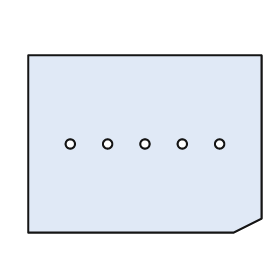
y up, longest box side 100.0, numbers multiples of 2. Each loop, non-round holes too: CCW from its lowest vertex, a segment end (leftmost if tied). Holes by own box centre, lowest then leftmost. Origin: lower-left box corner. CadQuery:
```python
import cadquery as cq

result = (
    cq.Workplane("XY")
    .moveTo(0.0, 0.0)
    .lineTo(88.0, 0.0)
    .lineTo(100.0, 6.0)
    .lineTo(100.0, 76.0)
    .lineTo(0.0, 76.0)
    .close()
    .moveTo(18.0, 38.0)
    .circle(2.0)
    .moveTo(34.0, 38.0)
    .circle(2.0)
    .moveTo(50.0, 38.0)
    .circle(2.0)
    .moveTo(66.0, 38.0)
    .circle(2.0)
    .moveTo(82.0, 38.0)
    .circle(2.0)
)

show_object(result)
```